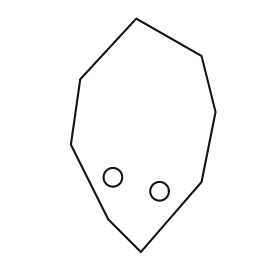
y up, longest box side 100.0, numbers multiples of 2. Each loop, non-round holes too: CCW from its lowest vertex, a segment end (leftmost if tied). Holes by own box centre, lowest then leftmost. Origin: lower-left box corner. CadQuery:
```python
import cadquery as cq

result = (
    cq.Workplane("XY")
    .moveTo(30.0, 0.0)
    .lineTo(56.0, 30.0)
    .lineTo(62.0, 60.0)
    .lineTo(56.0, 84.0)
    .lineTo(28.0, 100.0)
    .lineTo(4.0, 74.0)
    .lineTo(0.0, 46.0)
    .lineTo(16.0, 14.0)
    .close()
    .moveTo(38.0, 26.0)
    .circle(4.0)
    .moveTo(18.0, 32.0)
    .circle(4.0)
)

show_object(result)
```